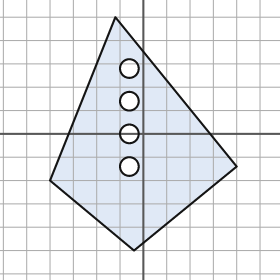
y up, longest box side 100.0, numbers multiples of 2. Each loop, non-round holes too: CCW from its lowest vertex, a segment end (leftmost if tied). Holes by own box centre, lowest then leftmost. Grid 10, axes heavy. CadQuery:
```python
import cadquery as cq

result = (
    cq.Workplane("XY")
    .moveTo(-4.0, -50.0)
    .lineTo(40.0, -14.0)
    .lineTo(-12.0, 50.0)
    .lineTo(-40.0, -20.0)
    .close()
    .moveTo(-6.0, -14.0)
    .circle(4.0)
    .moveTo(-6.0, 0.0)
    .circle(4.0)
    .moveTo(-6.0, 14.0)
    .circle(4.0)
    .moveTo(-6.0, 28.0)
    .circle(4.0)
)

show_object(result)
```